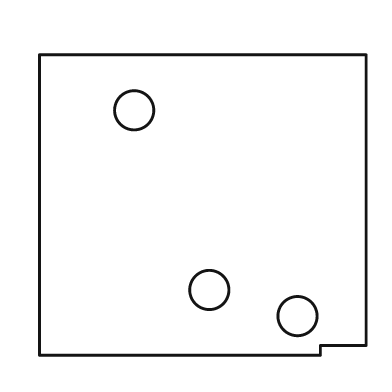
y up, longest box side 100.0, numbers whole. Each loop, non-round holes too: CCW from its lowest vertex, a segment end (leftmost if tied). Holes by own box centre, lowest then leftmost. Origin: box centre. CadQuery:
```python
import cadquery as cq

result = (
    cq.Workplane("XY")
    .moveTo(-50.0, -46.0)
    .lineTo(36.0, -46.0)
    .lineTo(36.0, -43.0)
    .lineTo(50.0, -43.0)
    .lineTo(50.0, 46.0)
    .lineTo(-50.0, 46.0)
    .close()
    .moveTo(29.0, -34.0)
    .circle(6.0)
    .moveTo(2.0, -26.0)
    .circle(6.0)
    .moveTo(-21.0, 29.0)
    .circle(6.0)
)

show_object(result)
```